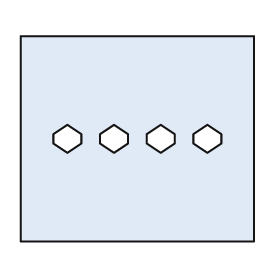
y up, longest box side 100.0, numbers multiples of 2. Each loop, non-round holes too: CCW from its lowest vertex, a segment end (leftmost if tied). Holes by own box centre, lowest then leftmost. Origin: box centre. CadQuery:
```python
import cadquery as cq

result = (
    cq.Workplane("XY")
    .moveTo(-50.0, -44.0)
    .lineTo(50.0, -44.0)
    .lineTo(50.0, 44.0)
    .lineTo(-50.0, 44.0)
    .close()
    .moveTo(-30.0, -6.0)
    .lineTo(-24.0, -2.0)
    .lineTo(-24.0, 2.0)
    .lineTo(-30.0, 6.0)
    .lineTo(-36.0, 2.0)
    .lineTo(-36.0, -2.0)
    .close()
    .moveTo(-10.0, -6.0)
    .lineTo(-4.0, -2.0)
    .lineTo(-4.0, 2.0)
    .lineTo(-10.0, 6.0)
    .lineTo(-16.0, 2.0)
    .lineTo(-16.0, -2.0)
    .close()
    .moveTo(10.0, -6.0)
    .lineTo(16.0, -2.0)
    .lineTo(16.0, 2.0)
    .lineTo(10.0, 6.0)
    .lineTo(4.0, 2.0)
    .lineTo(4.0, -2.0)
    .close()
    .moveTo(30.0, -6.0)
    .lineTo(36.0, -2.0)
    .lineTo(36.0, 2.0)
    .lineTo(30.0, 6.0)
    .lineTo(24.0, 2.0)
    .lineTo(24.0, -2.0)
    .close()
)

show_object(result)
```